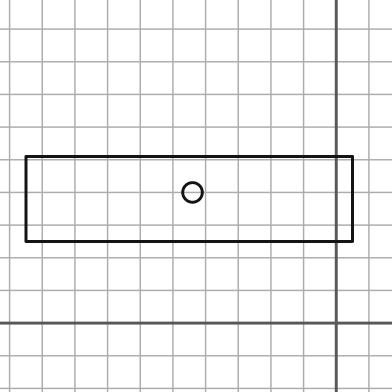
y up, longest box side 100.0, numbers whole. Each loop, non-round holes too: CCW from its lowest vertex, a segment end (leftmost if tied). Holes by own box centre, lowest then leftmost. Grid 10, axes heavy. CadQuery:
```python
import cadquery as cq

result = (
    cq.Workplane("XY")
    .moveTo(-95.0, 25.0)
    .lineTo(5.0, 25.0)
    .lineTo(5.0, 51.0)
    .lineTo(-95.0, 51.0)
    .close()
    .moveTo(-44.0, 40.0)
    .circle(3.0)
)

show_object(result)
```